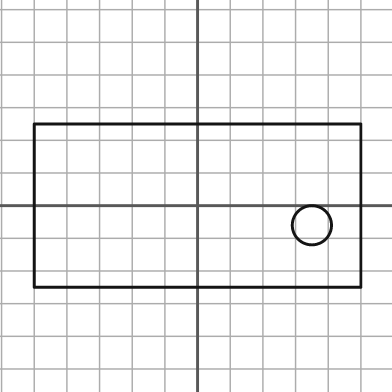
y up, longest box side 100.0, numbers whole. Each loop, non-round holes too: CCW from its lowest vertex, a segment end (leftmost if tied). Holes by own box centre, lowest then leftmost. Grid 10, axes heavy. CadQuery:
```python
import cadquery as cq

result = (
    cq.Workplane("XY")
    .moveTo(-50.0, -25.0)
    .lineTo(50.0, -25.0)
    .lineTo(50.0, 25.0)
    .lineTo(-50.0, 25.0)
    .close()
    .moveTo(35.0, -6.0)
    .circle(6.0)
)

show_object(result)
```